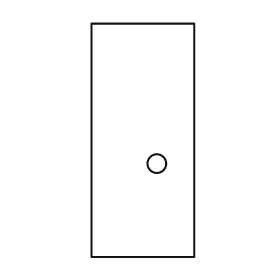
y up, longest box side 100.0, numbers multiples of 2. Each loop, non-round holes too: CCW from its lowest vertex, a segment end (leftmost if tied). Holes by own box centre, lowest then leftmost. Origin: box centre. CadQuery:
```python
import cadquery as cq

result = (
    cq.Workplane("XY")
    .moveTo(-22.0, -50.0)
    .lineTo(22.0, -50.0)
    .lineTo(22.0, 50.0)
    .lineTo(-22.0, 50.0)
    .close()
    .moveTo(6.0, -10.0)
    .circle(4.0)
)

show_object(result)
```